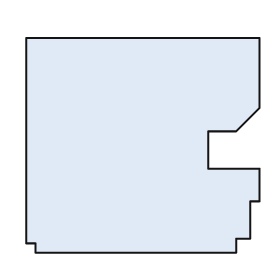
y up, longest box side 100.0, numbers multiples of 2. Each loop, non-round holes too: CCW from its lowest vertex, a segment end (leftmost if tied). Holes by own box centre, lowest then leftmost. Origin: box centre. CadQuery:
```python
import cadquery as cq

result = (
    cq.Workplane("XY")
    .moveTo(-46.0, -46.0)
    .lineTo(40.0, -46.0)
    .lineTo(40.0, -40.0)
    .lineTo(46.0, -40.0)
    .lineTo(46.0, -24.0)
    .lineTo(50.0, -24.0)
    .lineTo(50.0, -10.0)
    .lineTo(28.0, -10.0)
    .lineTo(28.0, 6.0)
    .lineTo(40.0, 6.0)
    .lineTo(50.0, 16.0)
    .lineTo(50.0, 46.0)
    .lineTo(-50.0, 46.0)
    .lineTo(-50.0, -42.0)
    .lineTo(-46.0, -42.0)
    .close()
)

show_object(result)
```